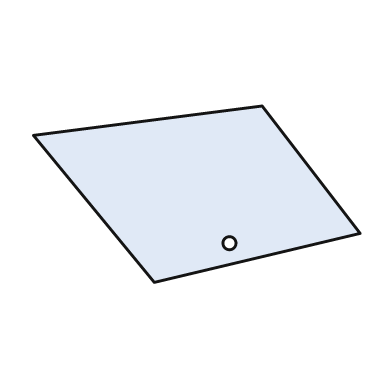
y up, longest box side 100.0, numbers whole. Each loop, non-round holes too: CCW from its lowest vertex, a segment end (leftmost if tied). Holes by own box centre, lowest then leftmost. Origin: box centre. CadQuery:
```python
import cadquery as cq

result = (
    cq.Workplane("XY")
    .moveTo(-13.0, -27.0)
    .lineTo(50.0, -12.0)
    .lineTo(20.0, 27.0)
    .lineTo(-50.0, 18.0)
    .close()
    .moveTo(10.0, -15.0)
    .circle(2.0)
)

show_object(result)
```